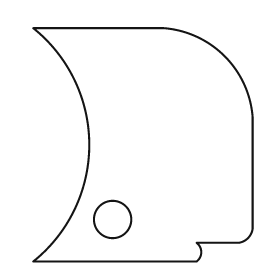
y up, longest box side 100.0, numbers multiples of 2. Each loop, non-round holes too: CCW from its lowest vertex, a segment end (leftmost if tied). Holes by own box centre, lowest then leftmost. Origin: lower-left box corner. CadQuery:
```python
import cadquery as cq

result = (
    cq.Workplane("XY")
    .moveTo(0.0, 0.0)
    .lineTo(70.0, 0.0)
    .threePointArc((72.0, 4.0), (70.0, 8.0))
    .lineTo(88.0, 8.0)
    .threePointArc((92.0, 10.0), (94.0, 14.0))
    .lineTo(94.0, 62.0)
    .threePointArc((82.0, 88.0), (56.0, 100.0))
    .lineTo(0.0, 100.0)
    .threePointArc((24.0, 50.0), (0.0, 0.0))
    .close()
    .moveTo(34.0, 18.0)
    .circle(8.0)
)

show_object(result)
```